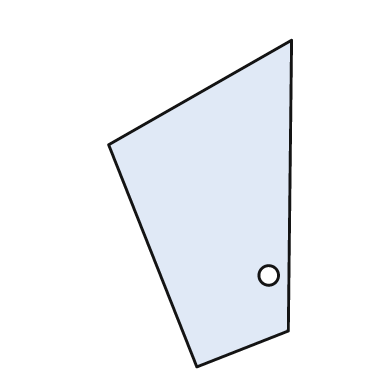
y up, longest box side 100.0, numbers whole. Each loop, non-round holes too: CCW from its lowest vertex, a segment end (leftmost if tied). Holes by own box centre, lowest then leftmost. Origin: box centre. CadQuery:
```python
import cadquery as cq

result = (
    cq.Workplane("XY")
    .moveTo(-1.0, -50.0)
    .lineTo(27.0, -39.0)
    .lineTo(28.0, 50.0)
    .lineTo(-28.0, 18.0)
    .close()
    .moveTo(21.0, -22.0)
    .circle(3.0)
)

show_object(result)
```